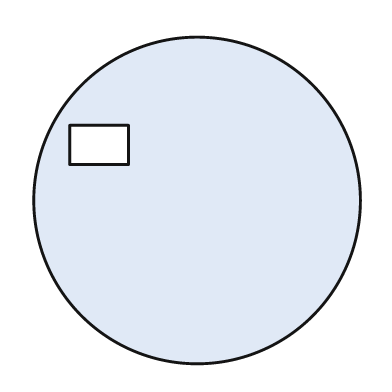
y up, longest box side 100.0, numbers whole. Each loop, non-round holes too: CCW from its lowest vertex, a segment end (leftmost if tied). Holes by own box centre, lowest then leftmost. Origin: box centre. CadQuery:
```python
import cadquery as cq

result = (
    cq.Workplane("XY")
    .moveTo(0.0, 0.0)
    .circle(50.0)
    .moveTo(-39.0, 11.0)
    .lineTo(-21.0, 11.0)
    .lineTo(-21.0, 23.0)
    .lineTo(-39.0, 23.0)
    .close()
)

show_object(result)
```